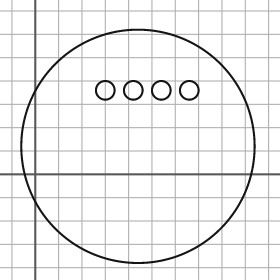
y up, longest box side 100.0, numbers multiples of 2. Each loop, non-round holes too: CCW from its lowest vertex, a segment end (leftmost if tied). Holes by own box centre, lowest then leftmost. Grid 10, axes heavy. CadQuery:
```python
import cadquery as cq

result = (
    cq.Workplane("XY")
    .moveTo(44.0, 12.0)
    .circle(50.0)
    .moveTo(30.0, 36.0)
    .circle(4.0)
    .moveTo(42.0, 36.0)
    .circle(4.0)
    .moveTo(54.0, 36.0)
    .circle(4.0)
    .moveTo(66.0, 36.0)
    .circle(4.0)
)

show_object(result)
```